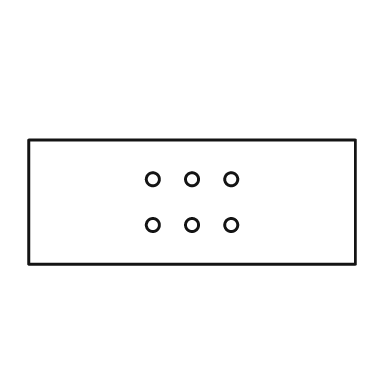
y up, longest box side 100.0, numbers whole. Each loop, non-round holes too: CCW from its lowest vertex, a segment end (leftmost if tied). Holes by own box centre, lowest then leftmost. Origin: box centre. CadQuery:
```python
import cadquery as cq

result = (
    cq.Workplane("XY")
    .moveTo(-50.0, -19.0)
    .lineTo(50.0, -19.0)
    .lineTo(50.0, 19.0)
    .lineTo(-50.0, 19.0)
    .close()
    .moveTo(-12.0, -7.0)
    .circle(2.0)
    .moveTo(0.0, -7.0)
    .circle(2.0)
    .moveTo(12.0, -7.0)
    .circle(2.0)
    .moveTo(-12.0, 7.0)
    .circle(2.0)
    .moveTo(0.0, 7.0)
    .circle(2.0)
    .moveTo(12.0, 7.0)
    .circle(2.0)
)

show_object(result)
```